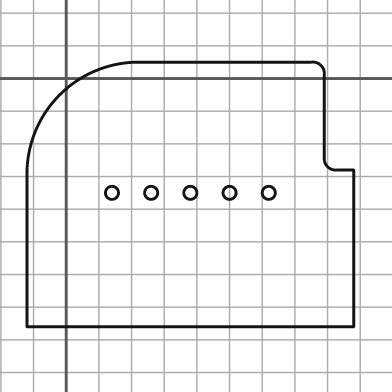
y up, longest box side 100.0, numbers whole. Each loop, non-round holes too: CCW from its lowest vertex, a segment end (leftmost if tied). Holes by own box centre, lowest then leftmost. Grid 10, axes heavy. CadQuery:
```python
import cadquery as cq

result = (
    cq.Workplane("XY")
    .moveTo(-12.0, -76.0)
    .lineTo(88.0, -76.0)
    .lineTo(88.0, -28.0)
    .lineTo(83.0, -28.0)
    .threePointArc((80.0, -27.0), (79.0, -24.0))
    .lineTo(79.0, 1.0)
    .threePointArc((78.0, 4.0), (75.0, 5.0))
    .lineTo(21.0, 5.0)
    .threePointArc((-2.0, -5.0), (-12.0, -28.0))
    .close()
    .moveTo(14.0, -35.0)
    .circle(2.0)
    .moveTo(26.0, -35.0)
    .circle(2.0)
    .moveTo(38.0, -35.0)
    .circle(2.0)
    .moveTo(50.0, -35.0)
    .circle(2.0)
    .moveTo(62.0, -35.0)
    .circle(2.0)
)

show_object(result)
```